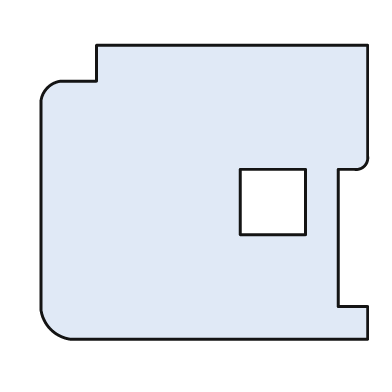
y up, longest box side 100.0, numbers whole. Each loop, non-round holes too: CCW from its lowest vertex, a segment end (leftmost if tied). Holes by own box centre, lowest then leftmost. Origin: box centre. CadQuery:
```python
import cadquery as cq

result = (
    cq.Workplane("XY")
    .moveTo(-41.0, -45.0)
    .lineTo(50.0, -45.0)
    .lineTo(50.0, -35.0)
    .lineTo(41.0, -35.0)
    .lineTo(41.0, 7.0)
    .lineTo(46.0, 7.0)
    .threePointArc((49.0, 8.0), (50.0, 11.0))
    .lineTo(50.0, 45.0)
    .lineTo(-33.0, 45.0)
    .lineTo(-33.0, 34.0)
    .lineTo(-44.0, 34.0)
    .threePointArc((-48.0, 32.0), (-50.0, 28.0))
    .lineTo(-50.0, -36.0)
    .threePointArc((-47.0, -42.0), (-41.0, -45.0))
    .close()
    .moveTo(11.0, -13.0)
    .lineTo(31.0, -13.0)
    .lineTo(31.0, 7.0)
    .lineTo(11.0, 7.0)
    .close()
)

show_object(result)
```